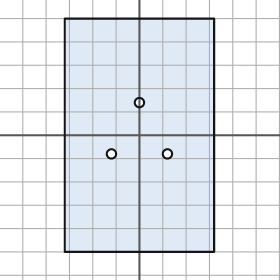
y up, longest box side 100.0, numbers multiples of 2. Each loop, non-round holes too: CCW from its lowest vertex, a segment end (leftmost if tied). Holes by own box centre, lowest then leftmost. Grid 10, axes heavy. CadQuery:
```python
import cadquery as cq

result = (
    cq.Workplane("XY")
    .moveTo(-32.0, -50.0)
    .lineTo(32.0, -50.0)
    .lineTo(32.0, 50.0)
    .lineTo(-32.0, 50.0)
    .close()
    .moveTo(-12.0, -8.0)
    .circle(2.0)
    .moveTo(12.0, -8.0)
    .circle(2.0)
    .moveTo(0.0, 14.0)
    .circle(2.0)
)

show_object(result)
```